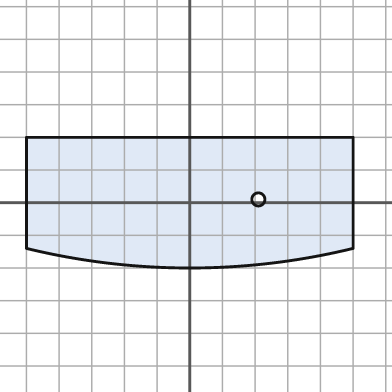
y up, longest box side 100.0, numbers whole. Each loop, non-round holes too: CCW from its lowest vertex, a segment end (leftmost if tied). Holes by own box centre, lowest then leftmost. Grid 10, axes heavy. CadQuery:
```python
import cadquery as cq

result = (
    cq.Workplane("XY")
    .moveTo(-50.0, -14.0)
    .threePointArc((0.0, -20.0), (50.0, -14.0))
    .lineTo(50.0, 20.0)
    .lineTo(-50.0, 20.0)
    .close()
    .moveTo(21.0, 1.0)
    .circle(2.0)
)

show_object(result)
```